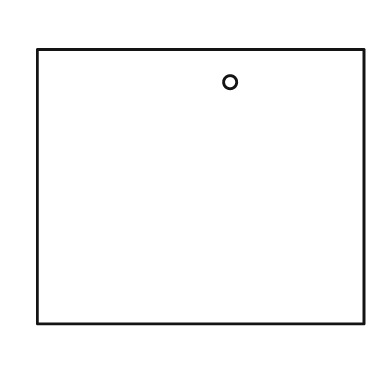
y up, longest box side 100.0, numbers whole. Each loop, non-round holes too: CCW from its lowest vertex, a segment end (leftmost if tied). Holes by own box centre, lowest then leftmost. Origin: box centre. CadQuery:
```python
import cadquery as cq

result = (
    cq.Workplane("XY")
    .moveTo(-50.0, -42.0)
    .lineTo(50.0, -42.0)
    .lineTo(50.0, 42.0)
    .lineTo(-50.0, 42.0)
    .close()
    .moveTo(9.0, 32.0)
    .circle(2.0)
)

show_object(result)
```